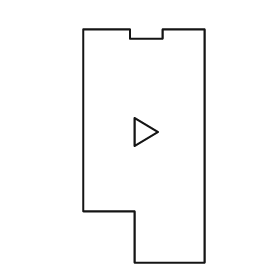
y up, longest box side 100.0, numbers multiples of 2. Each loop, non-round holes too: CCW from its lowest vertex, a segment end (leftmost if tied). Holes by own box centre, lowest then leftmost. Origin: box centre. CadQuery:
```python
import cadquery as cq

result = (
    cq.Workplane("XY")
    .moveTo(-4.0, -50.0)
    .lineTo(26.0, -50.0)
    .lineTo(26.0, 50.0)
    .lineTo(8.0, 50.0)
    .lineTo(8.0, 46.0)
    .lineTo(-6.0, 46.0)
    .lineTo(-6.0, 50.0)
    .lineTo(-26.0, 50.0)
    .lineTo(-26.0, -28.0)
    .lineTo(-4.0, -28.0)
    .close()
    .moveTo(-4.0, 0.0)
    .lineTo(6.0, 6.0)
    .lineTo(-4.0, 12.0)
    .close()
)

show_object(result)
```